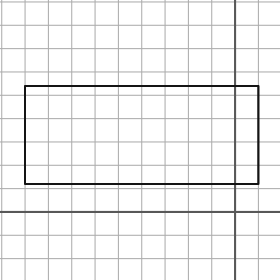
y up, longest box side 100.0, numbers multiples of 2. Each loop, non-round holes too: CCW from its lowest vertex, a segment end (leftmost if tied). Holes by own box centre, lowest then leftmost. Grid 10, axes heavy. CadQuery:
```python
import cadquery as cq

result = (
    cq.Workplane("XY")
    .moveTo(-90.0, 12.0)
    .lineTo(10.0, 12.0)
    .lineTo(10.0, 54.0)
    .lineTo(-90.0, 54.0)
    .close()
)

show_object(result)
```